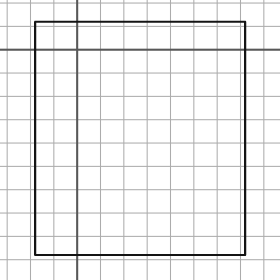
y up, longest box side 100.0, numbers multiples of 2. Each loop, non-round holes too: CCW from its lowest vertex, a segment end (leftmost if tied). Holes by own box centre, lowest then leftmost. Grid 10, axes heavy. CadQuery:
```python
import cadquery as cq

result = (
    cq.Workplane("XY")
    .moveTo(-18.0, -88.0)
    .lineTo(72.0, -88.0)
    .lineTo(72.0, 12.0)
    .lineTo(-18.0, 12.0)
    .close()
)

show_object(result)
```